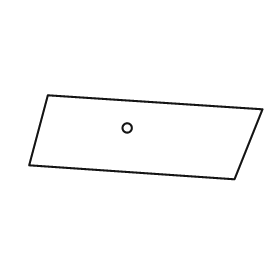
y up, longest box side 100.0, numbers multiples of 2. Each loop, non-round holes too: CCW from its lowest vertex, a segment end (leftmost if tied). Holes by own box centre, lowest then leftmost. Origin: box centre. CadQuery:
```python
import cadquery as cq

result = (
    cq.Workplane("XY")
    .moveTo(38.0, -18.0)
    .lineTo(50.0, 12.0)
    .lineTo(-42.0, 18.0)
    .lineTo(-50.0, -12.0)
    .close()
    .moveTo(-8.0, 4.0)
    .circle(2.0)
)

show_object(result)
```